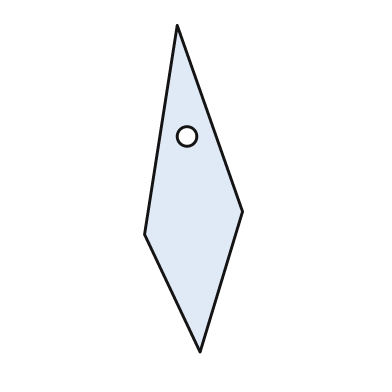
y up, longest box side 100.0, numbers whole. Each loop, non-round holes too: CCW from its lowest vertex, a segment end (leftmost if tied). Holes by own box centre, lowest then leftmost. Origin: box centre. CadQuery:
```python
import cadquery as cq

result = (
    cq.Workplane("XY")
    .moveTo(2.0, -50.0)
    .lineTo(15.0, -7.0)
    .lineTo(-5.0, 50.0)
    .lineTo(-15.0, -14.0)
    .close()
    .moveTo(-2.0, 16.0)
    .circle(3.0)
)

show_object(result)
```